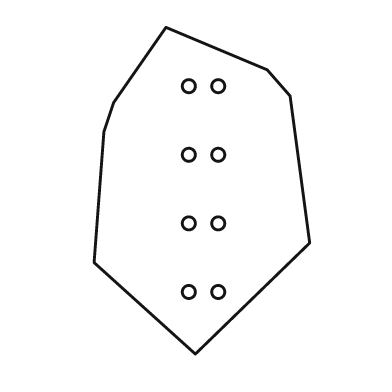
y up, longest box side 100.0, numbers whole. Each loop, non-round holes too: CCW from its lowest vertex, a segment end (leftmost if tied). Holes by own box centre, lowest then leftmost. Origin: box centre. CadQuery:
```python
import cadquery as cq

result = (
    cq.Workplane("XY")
    .moveTo(-2.0, -50.0)
    .lineTo(33.0, -16.0)
    .lineTo(27.0, 29.0)
    .lineTo(20.0, 37.0)
    .lineTo(-11.0, 50.0)
    .lineTo(-27.0, 27.0)
    .lineTo(-30.0, 18.0)
    .lineTo(-33.0, -22.0)
    .close()
    .moveTo(-4.0, -31.0)
    .circle(2.0)
    .moveTo(5.0, -31.0)
    .circle(2.0)
    .moveTo(-4.0, -10.0)
    .circle(2.0)
    .moveTo(5.0, -10.0)
    .circle(2.0)
    .moveTo(-4.0, 11.0)
    .circle(2.0)
    .moveTo(5.0, 11.0)
    .circle(2.0)
    .moveTo(-4.0, 32.0)
    .circle(2.0)
    .moveTo(5.0, 32.0)
    .circle(2.0)
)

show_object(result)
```